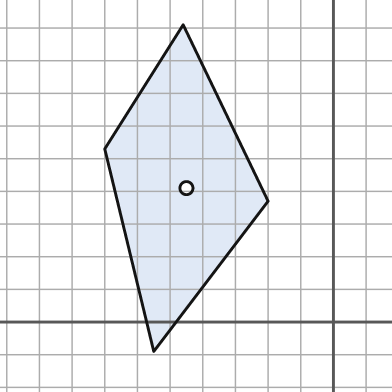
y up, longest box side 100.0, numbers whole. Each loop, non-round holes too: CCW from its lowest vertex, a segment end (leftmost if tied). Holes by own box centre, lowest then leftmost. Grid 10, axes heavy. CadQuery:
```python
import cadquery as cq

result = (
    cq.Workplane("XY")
    .moveTo(-55.0, -9.0)
    .lineTo(-20.0, 37.0)
    .lineTo(-46.0, 91.0)
    .lineTo(-70.0, 53.0)
    .close()
    .moveTo(-45.0, 41.0)
    .circle(2.0)
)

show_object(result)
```